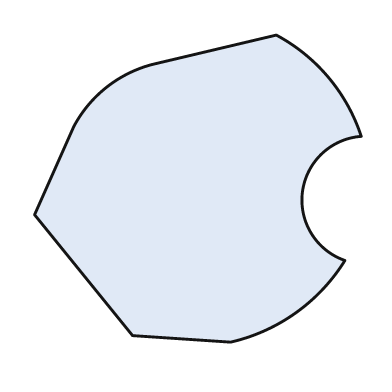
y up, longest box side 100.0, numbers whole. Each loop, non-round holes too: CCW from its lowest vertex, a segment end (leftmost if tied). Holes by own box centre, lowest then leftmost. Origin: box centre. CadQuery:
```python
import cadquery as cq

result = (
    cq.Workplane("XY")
    .moveTo(10.0, -47.0)
    .threePointArc((30.0, -38.0), (45.0, -22.0))
    .threePointArc((32.0, -1.0), (50.0, 16.0))
    .threePointArc((40.0, 34.0), (24.0, 47.0))
    .lineTo(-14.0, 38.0)
    .threePointArc((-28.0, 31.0), (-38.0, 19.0))
    .lineTo(-50.0, -8.0)
    .lineTo(-20.0, -45.0)
    .close()
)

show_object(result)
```